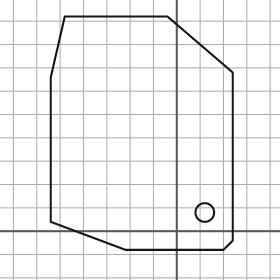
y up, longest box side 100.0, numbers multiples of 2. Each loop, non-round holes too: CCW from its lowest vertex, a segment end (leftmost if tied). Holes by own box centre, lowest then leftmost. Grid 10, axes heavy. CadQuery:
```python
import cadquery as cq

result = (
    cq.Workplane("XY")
    .moveTo(-22.0, -8.0)
    .lineTo(20.0, -8.0)
    .lineTo(24.0, -4.0)
    .lineTo(24.0, 68.0)
    .lineTo(-4.0, 92.0)
    .lineTo(-48.0, 92.0)
    .lineTo(-54.0, 66.0)
    .lineTo(-54.0, 4.0)
    .close()
    .moveTo(12.0, 8.0)
    .circle(4.0)
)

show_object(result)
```